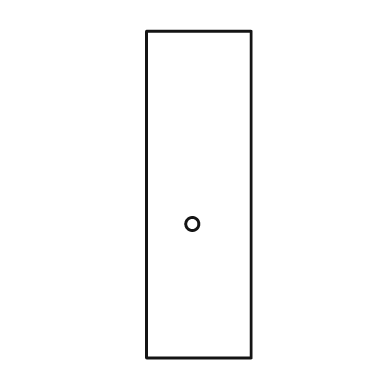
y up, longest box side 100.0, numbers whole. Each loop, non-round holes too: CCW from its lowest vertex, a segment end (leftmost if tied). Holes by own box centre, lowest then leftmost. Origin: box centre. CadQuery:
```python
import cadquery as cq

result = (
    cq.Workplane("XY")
    .moveTo(-16.0, -50.0)
    .lineTo(16.0, -50.0)
    .lineTo(16.0, 50.0)
    .lineTo(-16.0, 50.0)
    .close()
    .moveTo(-2.0, -9.0)
    .circle(2.0)
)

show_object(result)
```